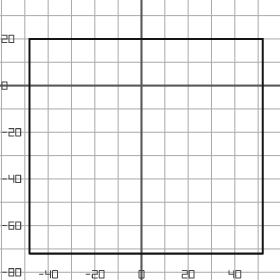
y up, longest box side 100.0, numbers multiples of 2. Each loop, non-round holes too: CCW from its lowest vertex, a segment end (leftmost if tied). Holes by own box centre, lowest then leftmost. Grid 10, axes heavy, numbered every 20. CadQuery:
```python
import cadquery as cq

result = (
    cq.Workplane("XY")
    .moveTo(-48.0, -72.0)
    .lineTo(52.0, -72.0)
    .lineTo(52.0, 20.0)
    .lineTo(-48.0, 20.0)
    .close()
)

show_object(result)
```